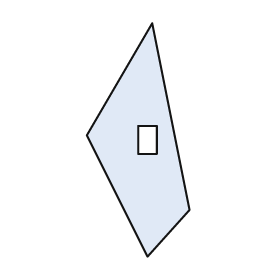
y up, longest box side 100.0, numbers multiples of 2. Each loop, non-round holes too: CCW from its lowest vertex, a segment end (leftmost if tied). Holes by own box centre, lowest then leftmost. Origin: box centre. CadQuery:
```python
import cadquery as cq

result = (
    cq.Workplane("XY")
    .moveTo(4.0, -50.0)
    .lineTo(22.0, -30.0)
    .lineTo(6.0, 50.0)
    .lineTo(-22.0, 2.0)
    .close()
    .moveTo(0.0, -6.0)
    .lineTo(8.0, -6.0)
    .lineTo(8.0, 6.0)
    .lineTo(0.0, 6.0)
    .close()
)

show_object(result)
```